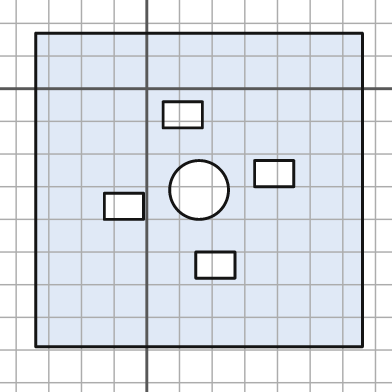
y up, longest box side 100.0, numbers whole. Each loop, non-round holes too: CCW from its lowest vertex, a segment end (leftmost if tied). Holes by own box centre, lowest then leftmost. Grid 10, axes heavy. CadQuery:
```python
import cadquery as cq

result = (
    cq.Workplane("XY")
    .moveTo(-34.0, -79.0)
    .lineTo(66.0, -79.0)
    .lineTo(66.0, 17.0)
    .lineTo(-34.0, 17.0)
    .close()
    .moveTo(15.0, -58.0)
    .lineTo(27.0, -58.0)
    .lineTo(27.0, -50.0)
    .lineTo(15.0, -50.0)
    .close()
    .moveTo(-13.0, -40.0)
    .lineTo(-1.0, -40.0)
    .lineTo(-1.0, -32.0)
    .lineTo(-13.0, -32.0)
    .close()
    .moveTo(16.0, -31.0)
    .circle(9.0)
    .moveTo(33.0, -30.0)
    .lineTo(45.0, -30.0)
    .lineTo(45.0, -22.0)
    .lineTo(33.0, -22.0)
    .close()
    .moveTo(5.0, -12.0)
    .lineTo(17.0, -12.0)
    .lineTo(17.0, -4.0)
    .lineTo(5.0, -4.0)
    .close()
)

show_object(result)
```